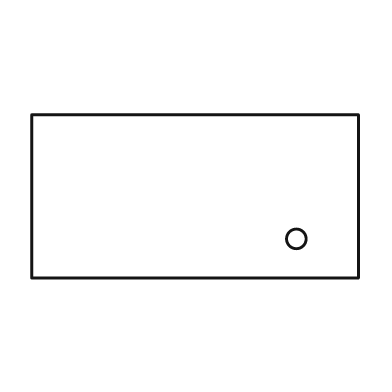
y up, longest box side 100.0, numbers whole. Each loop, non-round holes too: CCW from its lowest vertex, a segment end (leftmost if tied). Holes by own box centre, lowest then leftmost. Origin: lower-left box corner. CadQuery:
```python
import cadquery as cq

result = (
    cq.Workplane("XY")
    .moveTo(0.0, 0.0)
    .lineTo(100.0, 0.0)
    .lineTo(100.0, 50.0)
    .lineTo(0.0, 50.0)
    .close()
    .moveTo(81.0, 12.0)
    .circle(3.0)
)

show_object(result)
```